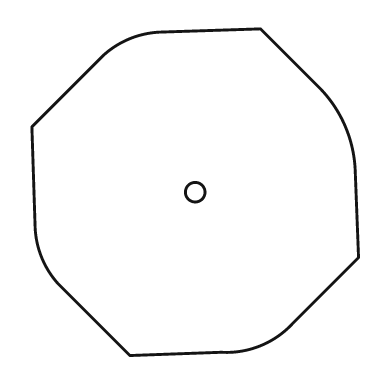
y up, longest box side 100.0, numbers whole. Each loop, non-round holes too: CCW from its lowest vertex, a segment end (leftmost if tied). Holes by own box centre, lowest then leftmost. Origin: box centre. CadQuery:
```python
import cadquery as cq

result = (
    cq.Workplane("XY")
    .moveTo(-20.0, -50.0)
    .lineTo(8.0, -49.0)
    .threePointArc((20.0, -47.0), (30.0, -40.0))
    .lineTo(50.0, -20.0)
    .lineTo(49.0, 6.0)
    .threePointArc((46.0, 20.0), (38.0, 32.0))
    .lineTo(20.0, 50.0)
    .lineTo(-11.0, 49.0)
    .threePointArc((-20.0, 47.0), (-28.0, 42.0))
    .lineTo(-50.0, 20.0)
    .lineTo(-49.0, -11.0)
    .threePointArc((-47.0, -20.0), (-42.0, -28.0))
    .close()
    .moveTo(0.0, 0.0)
    .circle(3.0)
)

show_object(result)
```